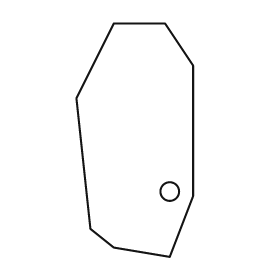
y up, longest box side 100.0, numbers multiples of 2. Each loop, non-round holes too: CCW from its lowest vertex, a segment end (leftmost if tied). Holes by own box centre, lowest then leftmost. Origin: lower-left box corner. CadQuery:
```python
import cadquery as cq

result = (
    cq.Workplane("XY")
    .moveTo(40.0, 0.0)
    .lineTo(50.0, 26.0)
    .lineTo(50.0, 82.0)
    .lineTo(38.0, 100.0)
    .lineTo(16.0, 100.0)
    .lineTo(0.0, 68.0)
    .lineTo(6.0, 12.0)
    .lineTo(16.0, 4.0)
    .close()
    .moveTo(40.0, 28.0)
    .circle(4.0)
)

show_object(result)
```